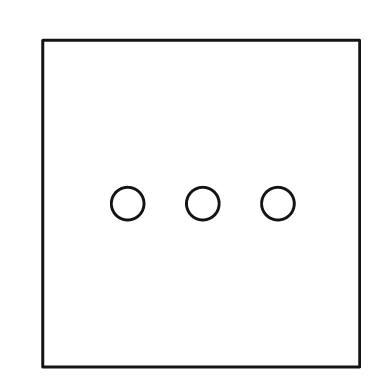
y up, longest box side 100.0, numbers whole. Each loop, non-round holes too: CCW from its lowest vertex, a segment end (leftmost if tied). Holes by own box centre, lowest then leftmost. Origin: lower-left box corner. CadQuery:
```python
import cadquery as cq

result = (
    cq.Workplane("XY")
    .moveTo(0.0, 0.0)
    .lineTo(97.0, 0.0)
    .lineTo(97.0, 100.0)
    .lineTo(0.0, 100.0)
    .close()
    .moveTo(26.0, 50.0)
    .circle(5.0)
    .moveTo(49.0, 50.0)
    .circle(5.0)
    .moveTo(72.0, 50.0)
    .circle(5.0)
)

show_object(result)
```